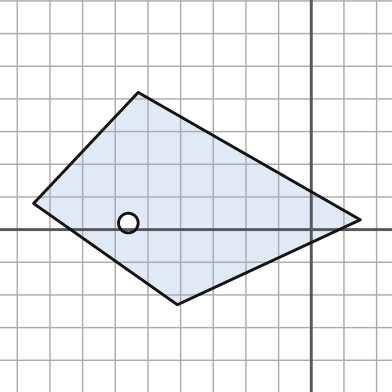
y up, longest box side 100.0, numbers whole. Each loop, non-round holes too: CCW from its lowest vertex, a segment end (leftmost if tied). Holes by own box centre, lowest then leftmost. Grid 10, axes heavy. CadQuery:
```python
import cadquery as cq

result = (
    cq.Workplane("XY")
    .moveTo(-41.0, -23.0)
    .lineTo(15.0, 3.0)
    .lineTo(-53.0, 42.0)
    .lineTo(-85.0, 8.0)
    .close()
    .moveTo(-56.0, 2.0)
    .circle(3.0)
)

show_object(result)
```